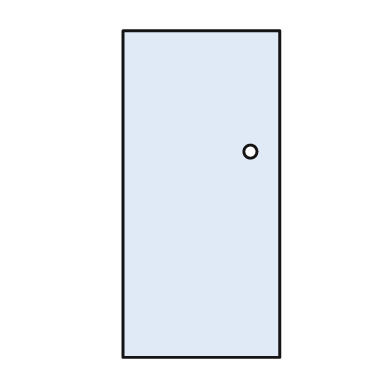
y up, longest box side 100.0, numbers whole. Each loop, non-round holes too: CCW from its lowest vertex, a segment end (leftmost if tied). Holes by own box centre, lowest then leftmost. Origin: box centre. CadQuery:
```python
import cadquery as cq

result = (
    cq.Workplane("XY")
    .moveTo(-24.0, -50.0)
    .lineTo(24.0, -50.0)
    .lineTo(24.0, 50.0)
    .lineTo(-24.0, 50.0)
    .close()
    .moveTo(15.0, 13.0)
    .circle(2.0)
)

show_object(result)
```